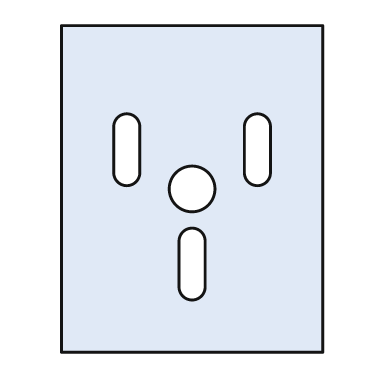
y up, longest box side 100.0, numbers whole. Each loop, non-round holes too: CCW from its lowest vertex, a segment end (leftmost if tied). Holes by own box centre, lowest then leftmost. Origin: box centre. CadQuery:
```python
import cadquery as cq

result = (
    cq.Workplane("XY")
    .moveTo(-40.0, -50.0)
    .lineTo(40.0, -50.0)
    .lineTo(40.0, 50.0)
    .lineTo(-40.0, 50.0)
    .close()
    .moveTo(-4.0, -30.0)
    .threePointArc((0.0, -34.0), (4.0, -30.0))
    .lineTo(4.0, -16.0)
    .threePointArc((0.0, -12.0), (-4.0, -16.0))
    .close()
    .moveTo(0.0, 0.0)
    .circle(7.0)
    .moveTo(-24.0, 5.0)
    .threePointArc((-20.0, 1.0), (-16.0, 5.0))
    .lineTo(-16.0, 19.0)
    .threePointArc((-20.0, 23.0), (-24.0, 19.0))
    .close()
    .moveTo(16.0, 5.0)
    .threePointArc((20.0, 1.0), (24.0, 5.0))
    .lineTo(24.0, 19.0)
    .threePointArc((20.0, 23.0), (16.0, 19.0))
    .close()
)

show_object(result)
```